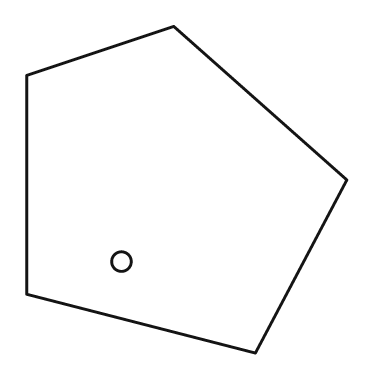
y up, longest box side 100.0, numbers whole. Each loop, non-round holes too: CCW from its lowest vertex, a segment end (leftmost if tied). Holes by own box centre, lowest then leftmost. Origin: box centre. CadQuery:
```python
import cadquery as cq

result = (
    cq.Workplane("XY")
    .moveTo(21.0, -50.0)
    .lineTo(49.0, 3.0)
    .lineTo(-4.0, 50.0)
    .lineTo(-49.0, 35.0)
    .lineTo(-49.0, -32.0)
    .close()
    .moveTo(-20.0, -22.0)
    .circle(3.0)
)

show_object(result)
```